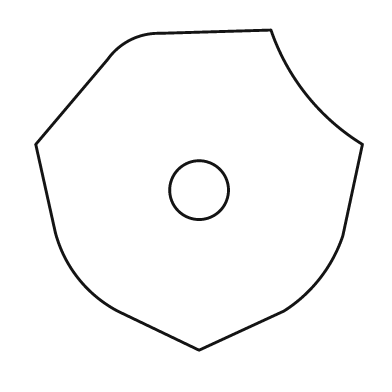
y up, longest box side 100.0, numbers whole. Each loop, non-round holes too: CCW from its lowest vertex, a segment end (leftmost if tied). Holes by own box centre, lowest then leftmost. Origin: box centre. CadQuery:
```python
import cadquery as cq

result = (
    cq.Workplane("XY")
    .moveTo(0.0, -49.0)
    .lineTo(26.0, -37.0)
    .threePointArc((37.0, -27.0), (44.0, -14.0))
    .lineTo(50.0, 14.0)
    .threePointArc((33.0, 29.0), (22.0, 49.0))
    .lineTo(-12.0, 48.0)
    .threePointArc((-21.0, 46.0), (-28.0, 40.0))
    .lineTo(-50.0, 14.0)
    .lineTo(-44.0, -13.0)
    .threePointArc((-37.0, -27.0), (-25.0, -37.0))
    .close()
    .moveTo(0.0, 0.0)
    .circle(9.0)
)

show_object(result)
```